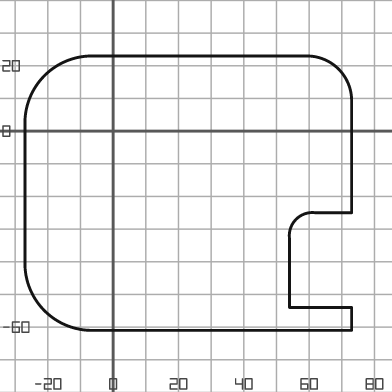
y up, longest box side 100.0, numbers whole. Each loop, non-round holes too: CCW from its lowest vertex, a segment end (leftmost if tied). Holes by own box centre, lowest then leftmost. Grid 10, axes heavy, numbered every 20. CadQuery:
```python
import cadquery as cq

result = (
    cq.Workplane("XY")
    .moveTo(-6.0, -61.0)
    .lineTo(73.0, -61.0)
    .lineTo(73.0, -54.0)
    .lineTo(54.0, -54.0)
    .lineTo(54.0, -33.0)
    .threePointArc((56.0, -27.0), (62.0, -25.0))
    .lineTo(73.0, -25.0)
    .lineTo(73.0, 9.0)
    .threePointArc((69.0, 19.0), (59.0, 23.0))
    .lineTo(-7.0, 23.0)
    .threePointArc((-21.0, 17.0), (-27.0, 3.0))
    .lineTo(-27.0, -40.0)
    .threePointArc((-21.0, -55.0), (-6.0, -61.0))
    .close()
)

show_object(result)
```